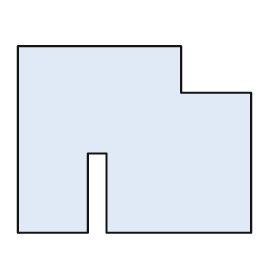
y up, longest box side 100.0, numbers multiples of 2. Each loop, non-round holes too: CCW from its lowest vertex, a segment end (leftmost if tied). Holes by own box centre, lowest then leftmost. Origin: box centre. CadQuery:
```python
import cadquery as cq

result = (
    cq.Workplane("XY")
    .moveTo(-50.0, -40.0)
    .lineTo(-20.0, -40.0)
    .lineTo(-20.0, -6.0)
    .lineTo(-12.0, -6.0)
    .lineTo(-12.0, -40.0)
    .lineTo(50.0, -40.0)
    .lineTo(50.0, 20.0)
    .lineTo(20.0, 20.0)
    .lineTo(20.0, 40.0)
    .lineTo(-50.0, 40.0)
    .close()
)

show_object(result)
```